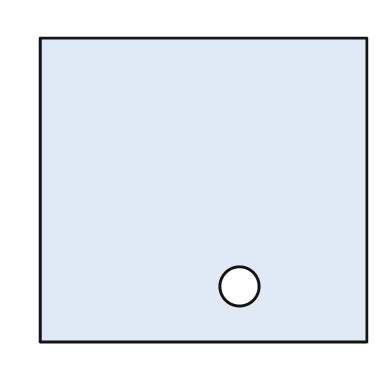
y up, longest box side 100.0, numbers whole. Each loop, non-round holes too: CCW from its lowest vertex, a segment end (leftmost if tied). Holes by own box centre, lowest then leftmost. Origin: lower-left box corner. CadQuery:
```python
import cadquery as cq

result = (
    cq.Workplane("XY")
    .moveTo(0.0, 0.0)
    .lineTo(100.0, 0.0)
    .lineTo(100.0, 93.0)
    .lineTo(0.0, 93.0)
    .close()
    .moveTo(61.0, 17.0)
    .circle(6.0)
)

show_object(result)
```